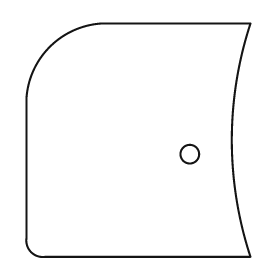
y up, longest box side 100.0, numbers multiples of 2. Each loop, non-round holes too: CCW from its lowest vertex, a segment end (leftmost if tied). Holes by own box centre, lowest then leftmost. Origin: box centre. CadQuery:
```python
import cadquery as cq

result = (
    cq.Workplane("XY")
    .moveTo(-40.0, -50.0)
    .lineTo(48.0, -50.0)
    .threePointArc((40.0, 0.0), (48.0, 50.0))
    .lineTo(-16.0, 50.0)
    .threePointArc((-38.0, 40.0), (-48.0, 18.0))
    .lineTo(-48.0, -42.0)
    .threePointArc((-46.0, -48.0), (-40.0, -50.0))
    .close()
    .moveTo(22.0, -6.0)
    .circle(4.0)
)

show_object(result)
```